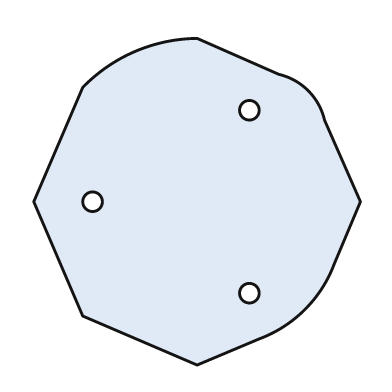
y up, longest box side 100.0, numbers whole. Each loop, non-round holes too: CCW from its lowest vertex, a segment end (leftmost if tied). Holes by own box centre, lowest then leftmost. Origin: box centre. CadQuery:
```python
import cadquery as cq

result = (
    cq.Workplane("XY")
    .moveTo(0.0, -50.0)
    .lineTo(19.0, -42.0)
    .threePointArc((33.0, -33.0), (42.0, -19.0))
    .lineTo(50.0, 0.0)
    .lineTo(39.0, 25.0)
    .threePointArc((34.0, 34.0), (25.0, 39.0))
    .lineTo(0.0, 50.0)
    .threePointArc((-19.0, 46.0), (-35.0, 35.0))
    .lineTo(-50.0, 0.0)
    .lineTo(-35.0, -35.0)
    .close()
    .moveTo(16.0, -28.0)
    .circle(3.0)
    .moveTo(-32.0, 0.0)
    .circle(3.0)
    .moveTo(16.0, 28.0)
    .circle(3.0)
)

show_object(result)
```